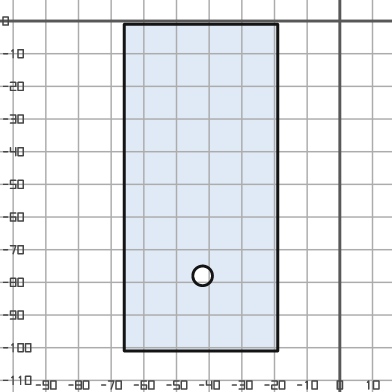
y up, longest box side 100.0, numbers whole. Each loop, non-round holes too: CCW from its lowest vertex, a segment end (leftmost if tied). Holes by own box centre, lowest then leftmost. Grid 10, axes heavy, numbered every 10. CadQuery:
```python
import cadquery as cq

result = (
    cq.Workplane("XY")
    .moveTo(-66.0, -101.0)
    .lineTo(-19.0, -101.0)
    .lineTo(-19.0, -1.0)
    .lineTo(-66.0, -1.0)
    .close()
    .moveTo(-42.0, -78.0)
    .circle(3.0)
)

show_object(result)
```